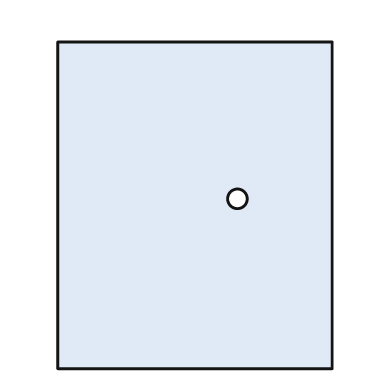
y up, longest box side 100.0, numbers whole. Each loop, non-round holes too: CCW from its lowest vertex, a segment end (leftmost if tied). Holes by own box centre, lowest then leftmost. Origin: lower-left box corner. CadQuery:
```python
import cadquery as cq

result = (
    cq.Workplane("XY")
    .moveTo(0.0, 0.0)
    .lineTo(84.0, 0.0)
    .lineTo(84.0, 100.0)
    .lineTo(0.0, 100.0)
    .close()
    .moveTo(55.0, 52.0)
    .circle(3.0)
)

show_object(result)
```